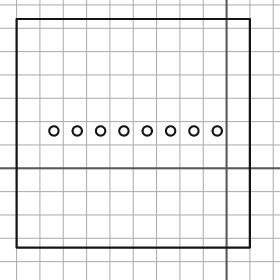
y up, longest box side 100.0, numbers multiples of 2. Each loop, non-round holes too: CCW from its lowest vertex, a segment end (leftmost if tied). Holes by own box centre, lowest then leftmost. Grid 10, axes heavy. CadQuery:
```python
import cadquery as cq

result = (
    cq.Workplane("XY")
    .moveTo(-90.0, -34.0)
    .lineTo(10.0, -34.0)
    .lineTo(10.0, 64.0)
    .lineTo(-90.0, 64.0)
    .close()
    .moveTo(-74.0, 16.0)
    .circle(2.0)
    .moveTo(-64.0, 16.0)
    .circle(2.0)
    .moveTo(-54.0, 16.0)
    .circle(2.0)
    .moveTo(-44.0, 16.0)
    .circle(2.0)
    .moveTo(-34.0, 16.0)
    .circle(2.0)
    .moveTo(-24.0, 16.0)
    .circle(2.0)
    .moveTo(-14.0, 16.0)
    .circle(2.0)
    .moveTo(-4.0, 16.0)
    .circle(2.0)
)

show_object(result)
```